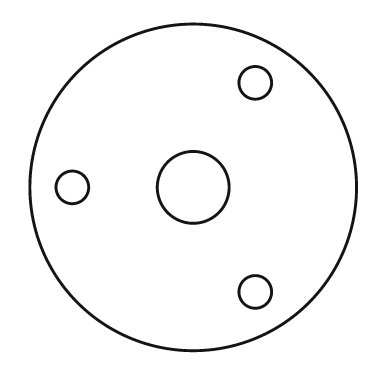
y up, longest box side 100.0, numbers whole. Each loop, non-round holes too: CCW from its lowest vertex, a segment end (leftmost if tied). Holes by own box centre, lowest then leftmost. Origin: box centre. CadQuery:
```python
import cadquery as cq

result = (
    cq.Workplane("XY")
    .moveTo(0.0, 0.0)
    .circle(50.0)
    .moveTo(19.0, -32.0)
    .circle(5.0)
    .moveTo(-37.0, 0.0)
    .circle(5.0)
    .moveTo(0.0, 0.0)
    .circle(11.0)
    .moveTo(19.0, 32.0)
    .circle(5.0)
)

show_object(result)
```